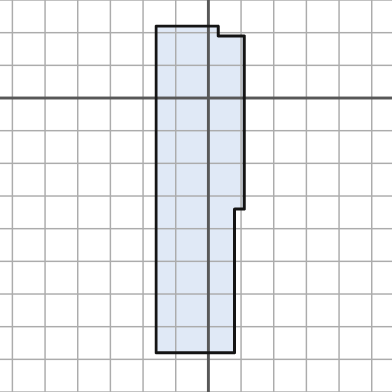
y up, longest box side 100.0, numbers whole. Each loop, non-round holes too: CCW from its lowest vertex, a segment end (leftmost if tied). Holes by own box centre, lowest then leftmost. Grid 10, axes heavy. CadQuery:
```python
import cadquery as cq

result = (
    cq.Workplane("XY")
    .moveTo(-16.0, -78.0)
    .lineTo(8.0, -78.0)
    .lineTo(8.0, -34.0)
    .lineTo(11.0, -34.0)
    .lineTo(11.0, 19.0)
    .lineTo(3.0, 19.0)
    .lineTo(3.0, 22.0)
    .lineTo(-16.0, 22.0)
    .close()
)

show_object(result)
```